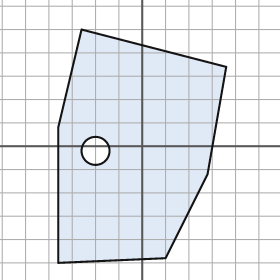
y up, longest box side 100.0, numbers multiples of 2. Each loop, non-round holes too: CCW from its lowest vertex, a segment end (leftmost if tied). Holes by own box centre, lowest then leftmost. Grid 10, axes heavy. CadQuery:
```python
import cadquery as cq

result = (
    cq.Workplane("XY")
    .moveTo(-36.0, -50.0)
    .lineTo(10.0, -48.0)
    .lineTo(28.0, -12.0)
    .lineTo(36.0, 34.0)
    .lineTo(-26.0, 50.0)
    .lineTo(-36.0, 8.0)
    .close()
    .moveTo(-20.0, -2.0)
    .circle(6.0)
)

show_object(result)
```